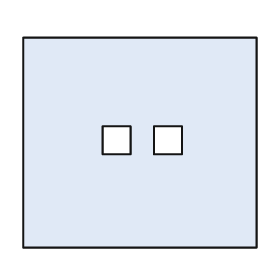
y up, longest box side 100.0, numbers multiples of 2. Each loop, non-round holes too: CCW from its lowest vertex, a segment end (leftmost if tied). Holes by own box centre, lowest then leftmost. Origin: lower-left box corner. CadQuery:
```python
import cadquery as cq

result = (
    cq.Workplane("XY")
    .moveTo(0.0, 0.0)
    .lineTo(100.0, 0.0)
    .lineTo(100.0, 90.0)
    .lineTo(0.0, 90.0)
    .close()
    .moveTo(34.0, 40.0)
    .lineTo(46.0, 40.0)
    .lineTo(46.0, 52.0)
    .lineTo(34.0, 52.0)
    .close()
    .moveTo(56.0, 40.0)
    .lineTo(68.0, 40.0)
    .lineTo(68.0, 52.0)
    .lineTo(56.0, 52.0)
    .close()
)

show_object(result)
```